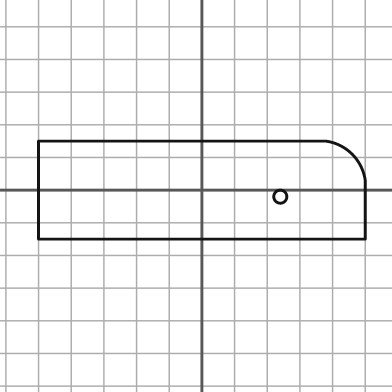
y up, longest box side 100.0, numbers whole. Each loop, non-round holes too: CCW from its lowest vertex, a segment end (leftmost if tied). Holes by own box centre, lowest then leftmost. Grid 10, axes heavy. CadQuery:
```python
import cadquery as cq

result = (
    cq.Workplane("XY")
    .moveTo(-50.0, -15.0)
    .lineTo(50.0, -15.0)
    .lineTo(50.0, 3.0)
    .threePointArc((46.0, 11.0), (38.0, 15.0))
    .lineTo(-50.0, 15.0)
    .close()
    .moveTo(24.0, -2.0)
    .circle(2.0)
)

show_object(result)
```